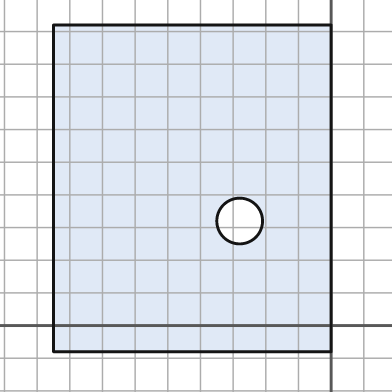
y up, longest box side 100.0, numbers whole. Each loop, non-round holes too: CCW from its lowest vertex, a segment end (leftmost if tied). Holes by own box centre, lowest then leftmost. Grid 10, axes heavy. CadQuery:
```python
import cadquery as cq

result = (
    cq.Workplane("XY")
    .moveTo(-85.0, -8.0)
    .lineTo(0.0, -8.0)
    .lineTo(0.0, 92.0)
    .lineTo(-85.0, 92.0)
    .close()
    .moveTo(-28.0, 32.0)
    .circle(7.0)
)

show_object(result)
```